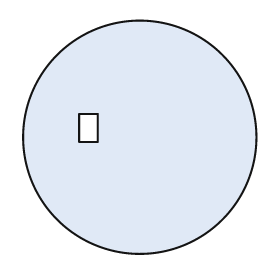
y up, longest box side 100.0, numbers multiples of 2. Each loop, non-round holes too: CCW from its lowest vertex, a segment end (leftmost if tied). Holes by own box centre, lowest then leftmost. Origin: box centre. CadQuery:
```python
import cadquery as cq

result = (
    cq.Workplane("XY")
    .moveTo(0.0, 0.0)
    .circle(50.0)
    .moveTo(-26.0, -2.0)
    .lineTo(-18.0, -2.0)
    .lineTo(-18.0, 10.0)
    .lineTo(-26.0, 10.0)
    .close()
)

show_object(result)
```